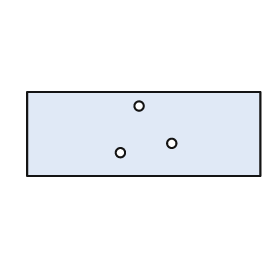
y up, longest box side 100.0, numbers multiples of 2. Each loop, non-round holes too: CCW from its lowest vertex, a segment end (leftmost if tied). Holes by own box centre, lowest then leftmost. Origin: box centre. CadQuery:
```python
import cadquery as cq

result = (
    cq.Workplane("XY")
    .moveTo(-50.0, -18.0)
    .lineTo(50.0, -18.0)
    .lineTo(50.0, 18.0)
    .lineTo(-50.0, 18.0)
    .close()
    .moveTo(-10.0, -8.0)
    .circle(2.0)
    .moveTo(12.0, -4.0)
    .circle(2.0)
    .moveTo(-2.0, 12.0)
    .circle(2.0)
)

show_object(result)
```